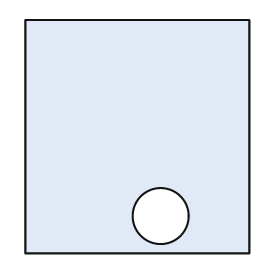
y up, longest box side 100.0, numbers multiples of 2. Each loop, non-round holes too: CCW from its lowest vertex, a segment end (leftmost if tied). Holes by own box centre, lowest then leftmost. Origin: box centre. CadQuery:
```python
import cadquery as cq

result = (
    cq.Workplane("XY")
    .moveTo(-48.0, -50.0)
    .lineTo(48.0, -50.0)
    .lineTo(48.0, 50.0)
    .lineTo(-48.0, 50.0)
    .close()
    .moveTo(10.0, -34.0)
    .circle(12.0)
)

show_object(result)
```